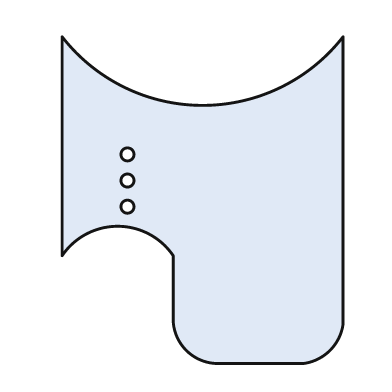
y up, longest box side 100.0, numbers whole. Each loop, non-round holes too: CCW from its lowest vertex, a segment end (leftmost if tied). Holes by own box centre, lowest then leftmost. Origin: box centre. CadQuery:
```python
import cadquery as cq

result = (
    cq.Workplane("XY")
    .moveTo(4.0, -50.0)
    .lineTo(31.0, -50.0)
    .threePointArc((39.0, -46.0), (43.0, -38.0))
    .lineTo(43.0, 50.0)
    .threePointArc((0.0, 29.0), (-43.0, 50.0))
    .lineTo(-43.0, -17.0)
    .threePointArc((-26.0, -8.0), (-9.0, -17.0))
    .lineTo(-9.0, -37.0)
    .threePointArc((-5.0, -46.0), (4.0, -50.0))
    .close()
    .moveTo(-23.0, -2.0)
    .circle(2.0)
    .moveTo(-23.0, 6.0)
    .circle(2.0)
    .moveTo(-23.0, 14.0)
    .circle(2.0)
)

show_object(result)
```